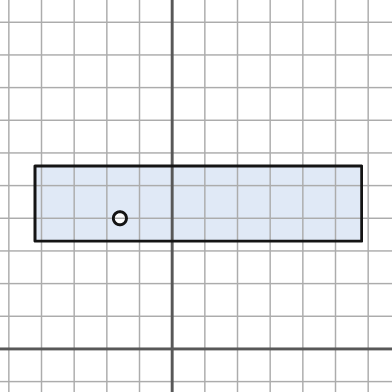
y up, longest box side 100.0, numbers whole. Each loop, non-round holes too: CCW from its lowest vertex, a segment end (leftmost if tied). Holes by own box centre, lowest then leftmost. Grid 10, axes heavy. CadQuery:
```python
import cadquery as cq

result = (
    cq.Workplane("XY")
    .moveTo(-42.0, 33.0)
    .lineTo(58.0, 33.0)
    .lineTo(58.0, 56.0)
    .lineTo(-42.0, 56.0)
    .close()
    .moveTo(-16.0, 40.0)
    .circle(2.0)
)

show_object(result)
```